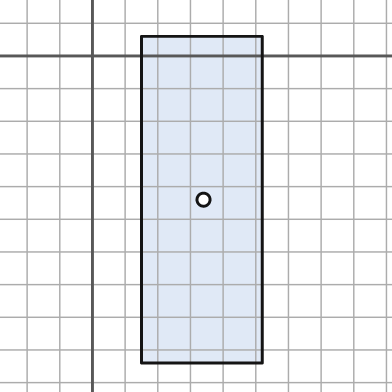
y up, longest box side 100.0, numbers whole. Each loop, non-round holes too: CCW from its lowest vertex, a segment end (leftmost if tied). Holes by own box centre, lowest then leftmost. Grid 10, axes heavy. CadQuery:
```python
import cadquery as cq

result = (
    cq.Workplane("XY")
    .moveTo(15.0, -94.0)
    .lineTo(52.0, -94.0)
    .lineTo(52.0, 6.0)
    .lineTo(15.0, 6.0)
    .close()
    .moveTo(34.0, -44.0)
    .circle(2.0)
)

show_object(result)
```